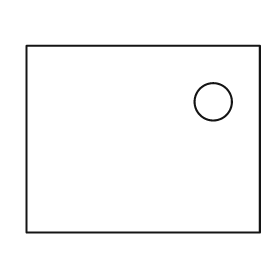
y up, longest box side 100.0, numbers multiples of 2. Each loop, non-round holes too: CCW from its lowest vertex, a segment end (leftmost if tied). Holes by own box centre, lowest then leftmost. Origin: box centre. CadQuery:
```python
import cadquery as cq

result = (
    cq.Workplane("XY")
    .moveTo(-50.0, -40.0)
    .lineTo(50.0, -40.0)
    .lineTo(50.0, 40.0)
    .lineTo(-50.0, 40.0)
    .close()
    .moveTo(30.0, 16.0)
    .circle(8.0)
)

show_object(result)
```